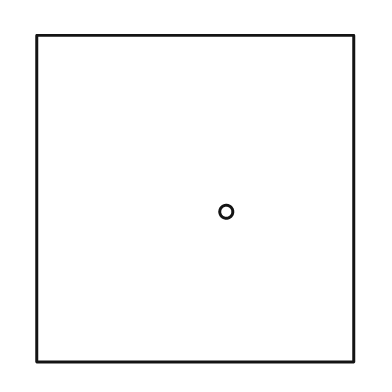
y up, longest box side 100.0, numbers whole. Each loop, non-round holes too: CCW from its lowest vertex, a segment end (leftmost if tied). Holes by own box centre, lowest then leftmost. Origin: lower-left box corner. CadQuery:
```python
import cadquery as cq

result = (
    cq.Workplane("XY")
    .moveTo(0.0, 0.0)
    .lineTo(97.0, 0.0)
    .lineTo(97.0, 100.0)
    .lineTo(0.0, 100.0)
    .close()
    .moveTo(58.0, 46.0)
    .circle(2.0)
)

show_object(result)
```